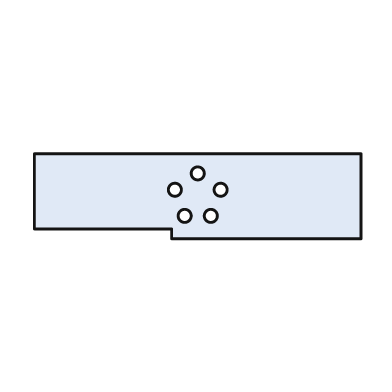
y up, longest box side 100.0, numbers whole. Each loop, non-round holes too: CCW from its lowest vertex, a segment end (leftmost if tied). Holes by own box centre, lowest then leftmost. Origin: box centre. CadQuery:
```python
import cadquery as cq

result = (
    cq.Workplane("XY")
    .moveTo(-8.0, -13.0)
    .lineTo(50.0, -13.0)
    .lineTo(50.0, 13.0)
    .lineTo(-50.0, 13.0)
    .lineTo(-50.0, -10.0)
    .lineTo(-8.0, -10.0)
    .close()
    .moveTo(-4.0, -6.0)
    .circle(2.0)
    .moveTo(4.0, -6.0)
    .circle(2.0)
    .moveTo(-7.0, 2.0)
    .circle(2.0)
    .moveTo(7.0, 2.0)
    .circle(2.0)
    .moveTo(0.0, 7.0)
    .circle(2.0)
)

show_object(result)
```